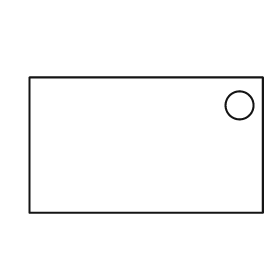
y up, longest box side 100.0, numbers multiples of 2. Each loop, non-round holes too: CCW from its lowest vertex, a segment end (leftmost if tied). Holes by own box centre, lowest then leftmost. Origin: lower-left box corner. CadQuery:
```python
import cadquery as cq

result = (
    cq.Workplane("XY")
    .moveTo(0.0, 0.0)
    .lineTo(100.0, 0.0)
    .lineTo(100.0, 58.0)
    .lineTo(0.0, 58.0)
    .close()
    .moveTo(90.0, 46.0)
    .circle(6.0)
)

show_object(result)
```